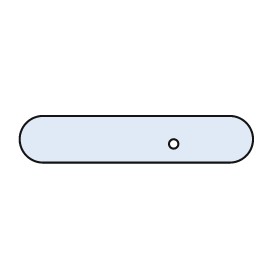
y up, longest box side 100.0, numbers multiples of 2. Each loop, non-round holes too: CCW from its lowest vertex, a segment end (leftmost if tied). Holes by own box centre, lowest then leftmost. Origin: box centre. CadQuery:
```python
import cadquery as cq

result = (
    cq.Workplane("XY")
    .moveTo(-40.0, -10.0)
    .lineTo(40.0, -10.0)
    .threePointArc((50.0, 0.0), (40.0, 10.0))
    .lineTo(-40.0, 10.0)
    .threePointArc((-50.0, 0.0), (-40.0, -10.0))
    .close()
    .moveTo(16.0, -2.0)
    .circle(2.0)
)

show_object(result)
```